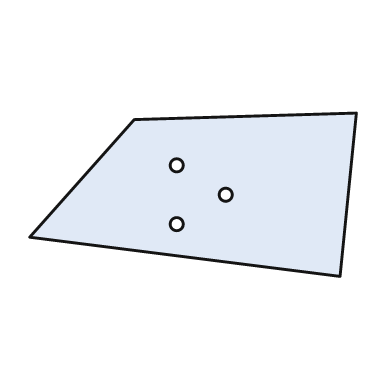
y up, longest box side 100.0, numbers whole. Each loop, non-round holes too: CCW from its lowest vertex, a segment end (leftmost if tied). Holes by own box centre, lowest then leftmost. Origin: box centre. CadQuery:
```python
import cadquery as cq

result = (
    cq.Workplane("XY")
    .moveTo(45.0, -25.0)
    .lineTo(50.0, 25.0)
    .lineTo(-18.0, 23.0)
    .lineTo(-50.0, -13.0)
    .close()
    .moveTo(-5.0, -9.0)
    .circle(2.0)
    .moveTo(10.0, 0.0)
    .circle(2.0)
    .moveTo(-5.0, 9.0)
    .circle(2.0)
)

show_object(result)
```